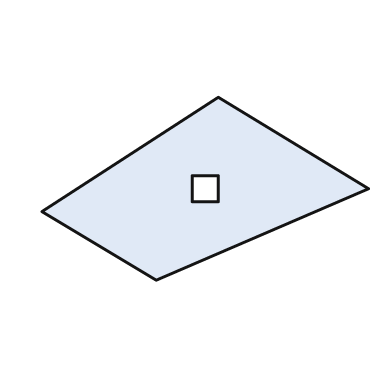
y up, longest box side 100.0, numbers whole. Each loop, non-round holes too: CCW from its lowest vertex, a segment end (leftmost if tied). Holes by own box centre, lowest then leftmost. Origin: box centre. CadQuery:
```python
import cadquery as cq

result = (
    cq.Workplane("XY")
    .moveTo(-15.0, -28.0)
    .lineTo(50.0, 0.0)
    .lineTo(4.0, 28.0)
    .lineTo(-50.0, -7.0)
    .close()
    .moveTo(-4.0, -4.0)
    .lineTo(4.0, -4.0)
    .lineTo(4.0, 4.0)
    .lineTo(-4.0, 4.0)
    .close()
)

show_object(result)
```